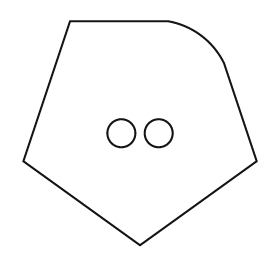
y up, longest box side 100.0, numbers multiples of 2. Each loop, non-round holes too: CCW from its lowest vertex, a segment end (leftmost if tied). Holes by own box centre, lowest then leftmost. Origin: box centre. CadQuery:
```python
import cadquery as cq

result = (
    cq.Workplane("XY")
    .moveTo(0.0, -48.0)
    .lineTo(50.0, -12.0)
    .lineTo(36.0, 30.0)
    .threePointArc((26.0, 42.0), (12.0, 48.0))
    .lineTo(-30.0, 48.0)
    .lineTo(-50.0, -12.0)
    .close()
    .moveTo(-8.0, 0.0)
    .circle(6.0)
    .moveTo(8.0, 0.0)
    .circle(6.0)
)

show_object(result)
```